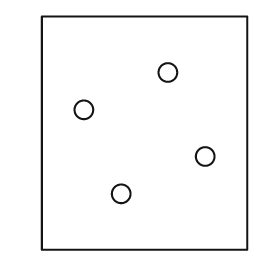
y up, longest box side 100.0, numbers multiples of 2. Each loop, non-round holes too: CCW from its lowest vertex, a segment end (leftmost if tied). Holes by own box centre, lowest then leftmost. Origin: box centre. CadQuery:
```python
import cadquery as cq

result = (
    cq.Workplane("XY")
    .moveTo(-44.0, -50.0)
    .lineTo(44.0, -50.0)
    .lineTo(44.0, 50.0)
    .lineTo(-44.0, 50.0)
    .close()
    .moveTo(-10.0, -26.0)
    .circle(4.0)
    .moveTo(26.0, -10.0)
    .circle(4.0)
    .moveTo(-26.0, 10.0)
    .circle(4.0)
    .moveTo(10.0, 26.0)
    .circle(4.0)
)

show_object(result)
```